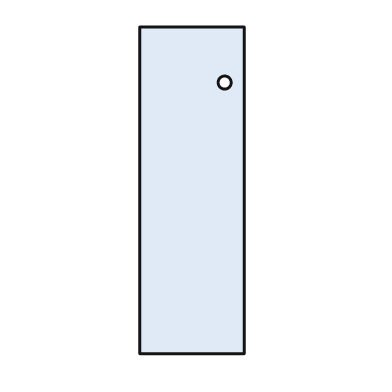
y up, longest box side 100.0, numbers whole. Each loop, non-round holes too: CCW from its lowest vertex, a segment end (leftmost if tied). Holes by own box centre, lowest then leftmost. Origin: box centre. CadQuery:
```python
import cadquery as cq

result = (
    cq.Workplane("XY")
    .moveTo(-16.0, -50.0)
    .lineTo(16.0, -50.0)
    .lineTo(16.0, 50.0)
    .lineTo(-16.0, 50.0)
    .close()
    .moveTo(10.0, 33.0)
    .circle(2.0)
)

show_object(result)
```